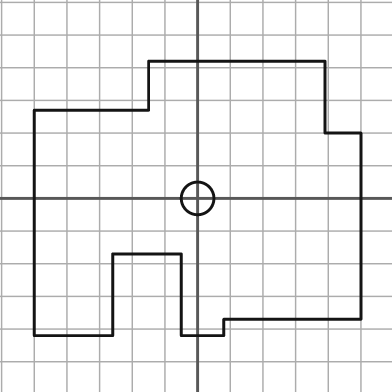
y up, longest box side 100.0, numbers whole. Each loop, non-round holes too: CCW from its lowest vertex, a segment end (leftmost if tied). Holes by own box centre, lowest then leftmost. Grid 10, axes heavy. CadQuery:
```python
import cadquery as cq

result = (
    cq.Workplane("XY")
    .moveTo(-50.0, -42.0)
    .lineTo(-26.0, -42.0)
    .lineTo(-26.0, -17.0)
    .lineTo(-5.0, -17.0)
    .lineTo(-5.0, -42.0)
    .lineTo(8.0, -42.0)
    .lineTo(8.0, -37.0)
    .lineTo(50.0, -37.0)
    .lineTo(50.0, 20.0)
    .lineTo(39.0, 20.0)
    .lineTo(39.0, 42.0)
    .lineTo(-15.0, 42.0)
    .lineTo(-15.0, 27.0)
    .lineTo(-50.0, 27.0)
    .close()
    .moveTo(0.0, 0.0)
    .circle(5.0)
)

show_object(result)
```